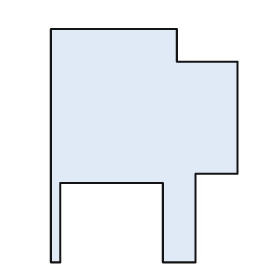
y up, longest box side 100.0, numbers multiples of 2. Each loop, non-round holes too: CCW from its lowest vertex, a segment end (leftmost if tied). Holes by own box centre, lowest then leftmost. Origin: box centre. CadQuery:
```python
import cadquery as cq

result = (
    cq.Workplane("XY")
    .moveTo(-40.0, -50.0)
    .lineTo(-36.0, -50.0)
    .lineTo(-36.0, -16.0)
    .lineTo(8.0, -16.0)
    .lineTo(8.0, -50.0)
    .lineTo(22.0, -50.0)
    .lineTo(22.0, -12.0)
    .lineTo(40.0, -12.0)
    .lineTo(40.0, 36.0)
    .lineTo(14.0, 36.0)
    .lineTo(14.0, 50.0)
    .lineTo(-40.0, 50.0)
    .close()
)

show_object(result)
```